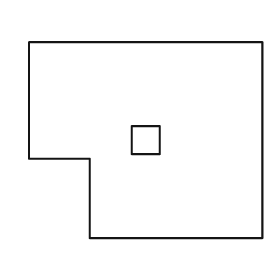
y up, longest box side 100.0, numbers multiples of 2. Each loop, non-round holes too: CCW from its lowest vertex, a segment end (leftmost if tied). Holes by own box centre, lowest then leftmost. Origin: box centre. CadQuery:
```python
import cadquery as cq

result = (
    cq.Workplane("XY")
    .moveTo(-24.0, -42.0)
    .lineTo(50.0, -42.0)
    .lineTo(50.0, 42.0)
    .lineTo(-50.0, 42.0)
    .lineTo(-50.0, -8.0)
    .lineTo(-24.0, -8.0)
    .close()
    .moveTo(-6.0, -6.0)
    .lineTo(6.0, -6.0)
    .lineTo(6.0, 6.0)
    .lineTo(-6.0, 6.0)
    .close()
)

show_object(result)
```